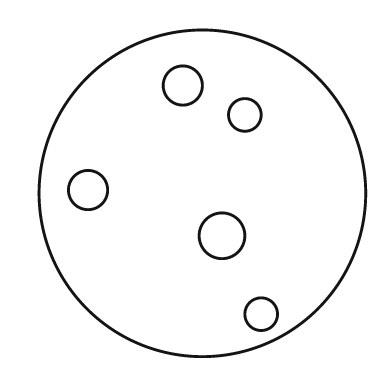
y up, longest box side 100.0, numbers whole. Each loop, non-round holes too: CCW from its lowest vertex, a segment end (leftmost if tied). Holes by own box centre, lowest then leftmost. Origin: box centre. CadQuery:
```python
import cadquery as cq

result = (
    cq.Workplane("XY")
    .moveTo(0.0, 0.0)
    .circle(50.0)
    .moveTo(18.0, -37.0)
    .circle(5.0)
    .moveTo(6.0, -13.0)
    .circle(7.0)
    .moveTo(-35.0, 1.0)
    .circle(6.0)
    .moveTo(13.0, 24.0)
    .circle(5.0)
    .moveTo(-6.0, 33.0)
    .circle(6.0)
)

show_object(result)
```